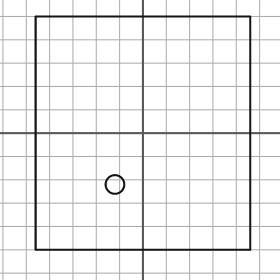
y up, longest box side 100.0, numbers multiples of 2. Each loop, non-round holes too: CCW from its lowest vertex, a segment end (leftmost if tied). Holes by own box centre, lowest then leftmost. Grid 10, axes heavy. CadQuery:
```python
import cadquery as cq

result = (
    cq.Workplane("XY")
    .moveTo(-46.0, -50.0)
    .lineTo(46.0, -50.0)
    .lineTo(46.0, 50.0)
    .lineTo(-46.0, 50.0)
    .close()
    .moveTo(-12.0, -22.0)
    .circle(4.0)
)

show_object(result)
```